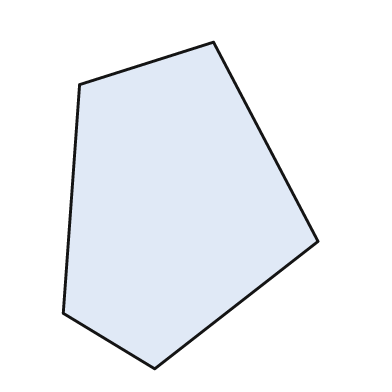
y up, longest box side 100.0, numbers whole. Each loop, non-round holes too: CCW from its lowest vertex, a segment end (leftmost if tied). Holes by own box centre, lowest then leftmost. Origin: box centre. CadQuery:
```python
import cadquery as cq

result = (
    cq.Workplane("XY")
    .moveTo(-11.0, -50.0)
    .lineTo(39.0, -11.0)
    .lineTo(7.0, 50.0)
    .lineTo(-34.0, 37.0)
    .lineTo(-39.0, -33.0)
    .close()
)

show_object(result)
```